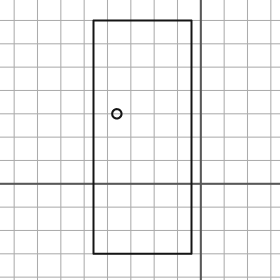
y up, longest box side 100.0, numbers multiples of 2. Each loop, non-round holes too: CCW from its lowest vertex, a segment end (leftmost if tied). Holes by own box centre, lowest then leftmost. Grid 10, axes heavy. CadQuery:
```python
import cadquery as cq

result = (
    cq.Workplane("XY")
    .moveTo(-46.0, -30.0)
    .lineTo(-4.0, -30.0)
    .lineTo(-4.0, 70.0)
    .lineTo(-46.0, 70.0)
    .close()
    .moveTo(-36.0, 30.0)
    .circle(2.0)
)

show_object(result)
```